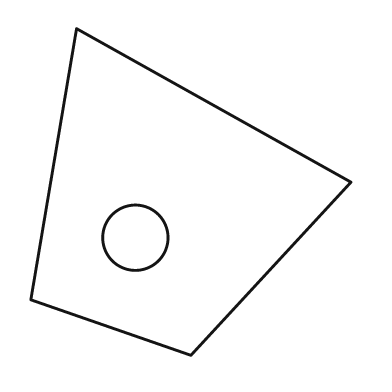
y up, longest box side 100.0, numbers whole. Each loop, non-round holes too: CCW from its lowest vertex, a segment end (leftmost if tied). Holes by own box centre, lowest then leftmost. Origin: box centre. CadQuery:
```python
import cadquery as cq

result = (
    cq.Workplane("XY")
    .moveTo(0.0, -50.0)
    .lineTo(49.0, 3.0)
    .lineTo(-35.0, 50.0)
    .lineTo(-49.0, -33.0)
    .close()
    .moveTo(-17.0, -14.0)
    .circle(10.0)
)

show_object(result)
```